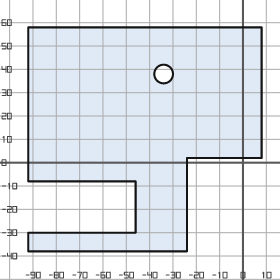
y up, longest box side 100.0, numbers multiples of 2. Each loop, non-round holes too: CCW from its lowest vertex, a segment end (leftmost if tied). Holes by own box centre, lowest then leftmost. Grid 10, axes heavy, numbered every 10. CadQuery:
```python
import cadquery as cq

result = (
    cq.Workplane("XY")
    .moveTo(-92.0, -38.0)
    .lineTo(-24.0, -38.0)
    .lineTo(-24.0, 2.0)
    .lineTo(8.0, 2.0)
    .lineTo(8.0, 58.0)
    .lineTo(-92.0, 58.0)
    .lineTo(-92.0, -8.0)
    .lineTo(-46.0, -8.0)
    .lineTo(-46.0, -30.0)
    .lineTo(-92.0, -30.0)
    .close()
    .moveTo(-34.0, 38.0)
    .circle(4.0)
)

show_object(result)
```